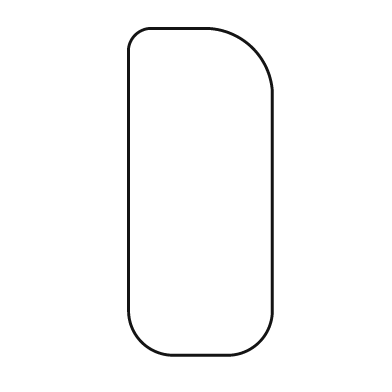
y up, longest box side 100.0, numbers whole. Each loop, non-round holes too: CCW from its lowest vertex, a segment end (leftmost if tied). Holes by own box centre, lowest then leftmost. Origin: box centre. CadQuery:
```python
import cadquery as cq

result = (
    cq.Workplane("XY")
    .moveTo(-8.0, -50.0)
    .lineTo(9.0, -50.0)
    .threePointArc((18.0, -46.0), (22.0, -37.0))
    .lineTo(22.0, 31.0)
    .threePointArc((16.0, 44.0), (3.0, 50.0))
    .lineTo(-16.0, 50.0)
    .threePointArc((-20.0, 48.0), (-22.0, 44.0))
    .lineTo(-22.0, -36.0)
    .threePointArc((-18.0, -46.0), (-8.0, -50.0))
    .close()
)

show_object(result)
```